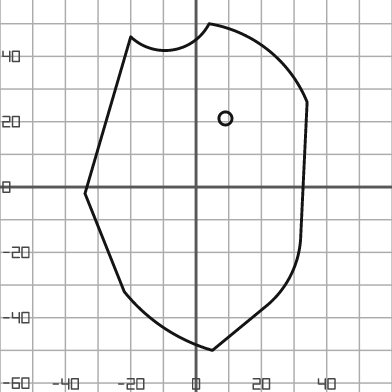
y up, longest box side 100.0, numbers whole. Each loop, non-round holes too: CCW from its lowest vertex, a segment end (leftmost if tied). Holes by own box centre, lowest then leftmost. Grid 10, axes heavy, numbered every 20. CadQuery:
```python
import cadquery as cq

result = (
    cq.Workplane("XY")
    .moveTo(5.0, -50.0)
    .lineTo(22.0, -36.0)
    .threePointArc((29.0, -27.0), (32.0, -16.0))
    .lineTo(34.0, 26.0)
    .threePointArc((22.0, 42.0), (4.0, 50.0))
    .threePointArc((-7.0, 42.0), (-20.0, 46.0))
    .lineTo(-34.0, -2.0)
    .lineTo(-22.0, -32.0)
    .threePointArc((-10.0, -43.0), (5.0, -50.0))
    .close()
    .moveTo(9.0, 21.0)
    .circle(2.0)
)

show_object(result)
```